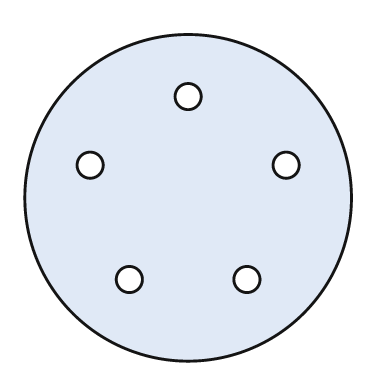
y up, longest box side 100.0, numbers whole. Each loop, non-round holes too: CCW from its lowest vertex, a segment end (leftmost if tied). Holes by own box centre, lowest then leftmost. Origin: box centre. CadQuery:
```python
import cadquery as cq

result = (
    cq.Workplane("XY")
    .moveTo(0.0, 0.0)
    .circle(50.0)
    .moveTo(-18.0, -25.0)
    .circle(4.0)
    .moveTo(18.0, -25.0)
    .circle(4.0)
    .moveTo(-30.0, 10.0)
    .circle(4.0)
    .moveTo(30.0, 10.0)
    .circle(4.0)
    .moveTo(0.0, 31.0)
    .circle(4.0)
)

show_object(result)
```